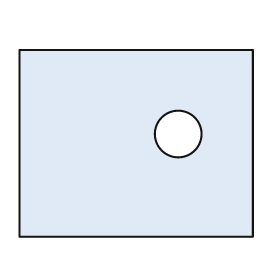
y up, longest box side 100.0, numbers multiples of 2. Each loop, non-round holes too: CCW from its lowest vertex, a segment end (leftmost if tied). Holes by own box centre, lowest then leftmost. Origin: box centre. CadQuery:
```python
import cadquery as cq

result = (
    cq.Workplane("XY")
    .moveTo(-50.0, -40.0)
    .lineTo(50.0, -40.0)
    .lineTo(50.0, 40.0)
    .lineTo(-50.0, 40.0)
    .close()
    .moveTo(18.0, 4.0)
    .circle(10.0)
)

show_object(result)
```